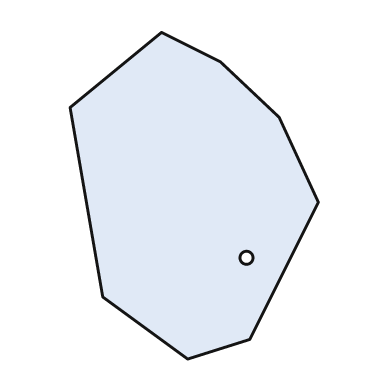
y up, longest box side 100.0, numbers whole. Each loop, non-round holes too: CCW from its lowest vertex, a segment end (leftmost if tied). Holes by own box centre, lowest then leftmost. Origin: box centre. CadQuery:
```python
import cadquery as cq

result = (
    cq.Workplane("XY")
    .moveTo(-2.0, -50.0)
    .lineTo(17.0, -44.0)
    .lineTo(38.0, -2.0)
    .lineTo(26.0, 24.0)
    .lineTo(8.0, 41.0)
    .lineTo(-10.0, 50.0)
    .lineTo(-38.0, 27.0)
    .lineTo(-28.0, -31.0)
    .close()
    .moveTo(16.0, -19.0)
    .circle(2.0)
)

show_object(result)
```